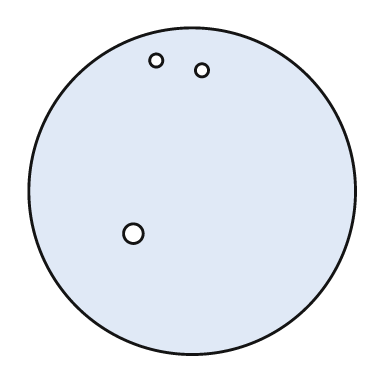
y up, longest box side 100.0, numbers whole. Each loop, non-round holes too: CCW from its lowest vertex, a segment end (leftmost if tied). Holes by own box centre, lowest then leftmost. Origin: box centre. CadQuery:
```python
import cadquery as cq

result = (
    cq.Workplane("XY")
    .moveTo(0.0, 0.0)
    .circle(50.0)
    .moveTo(-18.0, -13.0)
    .circle(3.0)
    .moveTo(3.0, 37.0)
    .circle(2.0)
    .moveTo(-11.0, 40.0)
    .circle(2.0)
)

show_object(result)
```